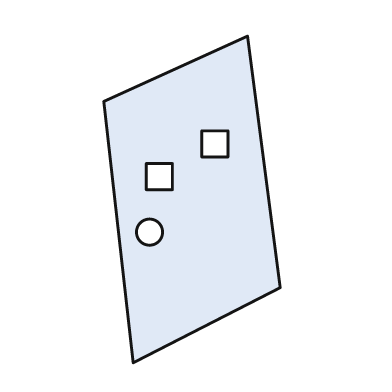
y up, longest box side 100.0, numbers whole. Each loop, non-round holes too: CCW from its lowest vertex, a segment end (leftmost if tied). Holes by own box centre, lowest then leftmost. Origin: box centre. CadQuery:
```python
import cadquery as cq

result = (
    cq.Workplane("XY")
    .moveTo(-18.0, -50.0)
    .lineTo(27.0, -27.0)
    .lineTo(17.0, 50.0)
    .lineTo(-27.0, 30.0)
    .close()
    .moveTo(-13.0, -10.0)
    .circle(4.0)
    .moveTo(-14.0, 3.0)
    .lineTo(-6.0, 3.0)
    .lineTo(-6.0, 11.0)
    .lineTo(-14.0, 11.0)
    .close()
    .moveTo(3.0, 13.0)
    .lineTo(11.0, 13.0)
    .lineTo(11.0, 21.0)
    .lineTo(3.0, 21.0)
    .close()
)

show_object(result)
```